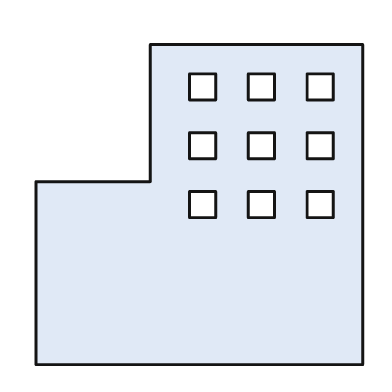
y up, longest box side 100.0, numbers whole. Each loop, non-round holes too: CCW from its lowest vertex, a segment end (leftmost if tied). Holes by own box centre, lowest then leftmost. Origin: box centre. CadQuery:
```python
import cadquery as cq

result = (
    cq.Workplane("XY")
    .moveTo(-50.0, -49.0)
    .lineTo(50.0, -49.0)
    .lineTo(50.0, 49.0)
    .lineTo(-15.0, 49.0)
    .lineTo(-15.0, 7.0)
    .lineTo(-50.0, 7.0)
    .close()
    .moveTo(-3.0, -4.0)
    .lineTo(5.0, -4.0)
    .lineTo(5.0, 4.0)
    .lineTo(-3.0, 4.0)
    .close()
    .moveTo(15.0, -4.0)
    .lineTo(23.0, -4.0)
    .lineTo(23.0, 4.0)
    .lineTo(15.0, 4.0)
    .close()
    .moveTo(33.0, -4.0)
    .lineTo(41.0, -4.0)
    .lineTo(41.0, 4.0)
    .lineTo(33.0, 4.0)
    .close()
    .moveTo(-3.0, 14.0)
    .lineTo(5.0, 14.0)
    .lineTo(5.0, 22.0)
    .lineTo(-3.0, 22.0)
    .close()
    .moveTo(15.0, 14.0)
    .lineTo(23.0, 14.0)
    .lineTo(23.0, 22.0)
    .lineTo(15.0, 22.0)
    .close()
    .moveTo(33.0, 14.0)
    .lineTo(41.0, 14.0)
    .lineTo(41.0, 22.0)
    .lineTo(33.0, 22.0)
    .close()
    .moveTo(-3.0, 32.0)
    .lineTo(5.0, 32.0)
    .lineTo(5.0, 40.0)
    .lineTo(-3.0, 40.0)
    .close()
    .moveTo(15.0, 32.0)
    .lineTo(23.0, 32.0)
    .lineTo(23.0, 40.0)
    .lineTo(15.0, 40.0)
    .close()
    .moveTo(33.0, 32.0)
    .lineTo(41.0, 32.0)
    .lineTo(41.0, 40.0)
    .lineTo(33.0, 40.0)
    .close()
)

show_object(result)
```